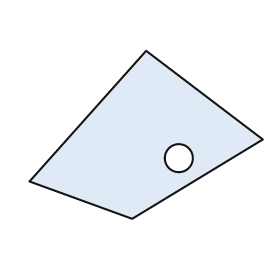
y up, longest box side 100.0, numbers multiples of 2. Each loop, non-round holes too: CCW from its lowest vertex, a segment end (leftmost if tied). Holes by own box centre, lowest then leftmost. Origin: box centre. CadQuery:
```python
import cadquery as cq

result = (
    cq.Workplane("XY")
    .moveTo(-6.0, -36.0)
    .lineTo(50.0, -2.0)
    .lineTo(0.0, 36.0)
    .lineTo(-50.0, -20.0)
    .close()
    .moveTo(14.0, -10.0)
    .circle(6.0)
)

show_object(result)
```